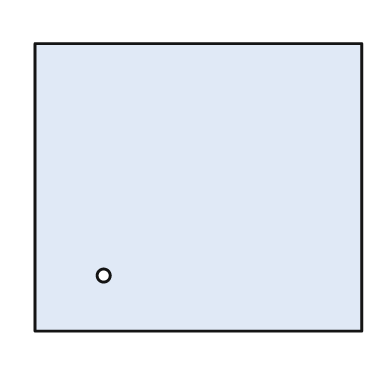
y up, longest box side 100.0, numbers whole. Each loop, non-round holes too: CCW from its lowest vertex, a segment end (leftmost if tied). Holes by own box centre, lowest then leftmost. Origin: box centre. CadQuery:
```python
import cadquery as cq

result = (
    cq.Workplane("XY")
    .moveTo(-50.0, -44.0)
    .lineTo(50.0, -44.0)
    .lineTo(50.0, 44.0)
    .lineTo(-50.0, 44.0)
    .close()
    .moveTo(-29.0, -27.0)
    .circle(2.0)
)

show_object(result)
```